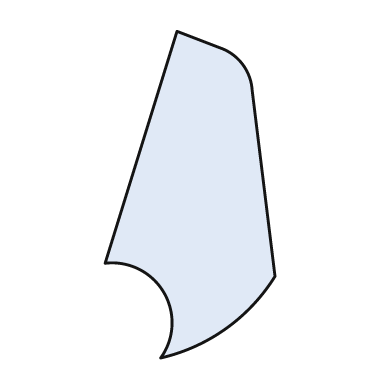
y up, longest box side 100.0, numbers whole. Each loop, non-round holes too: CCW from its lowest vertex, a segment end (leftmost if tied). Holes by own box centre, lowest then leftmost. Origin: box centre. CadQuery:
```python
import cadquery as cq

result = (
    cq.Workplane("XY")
    .moveTo(-9.0, -50.0)
    .threePointArc((11.0, -41.0), (26.0, -25.0))
    .lineTo(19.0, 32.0)
    .threePointArc((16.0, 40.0), (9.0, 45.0))
    .lineTo(-4.0, 50.0)
    .lineTo(-26.0, -21.0)
    .threePointArc((-8.0, -30.0), (-9.0, -50.0))
    .close()
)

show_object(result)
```